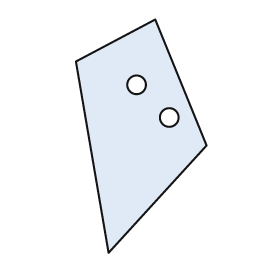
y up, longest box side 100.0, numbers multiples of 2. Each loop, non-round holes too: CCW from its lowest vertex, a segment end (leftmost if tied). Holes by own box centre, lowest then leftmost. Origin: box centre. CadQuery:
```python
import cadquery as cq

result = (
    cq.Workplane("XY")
    .moveTo(-14.0, -50.0)
    .lineTo(28.0, -4.0)
    .lineTo(6.0, 50.0)
    .lineTo(-28.0, 32.0)
    .close()
    .moveTo(12.0, 8.0)
    .circle(4.0)
    .moveTo(-2.0, 22.0)
    .circle(4.0)
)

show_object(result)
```